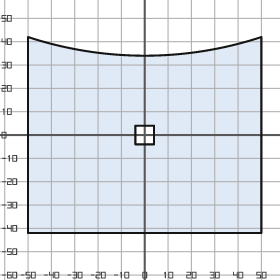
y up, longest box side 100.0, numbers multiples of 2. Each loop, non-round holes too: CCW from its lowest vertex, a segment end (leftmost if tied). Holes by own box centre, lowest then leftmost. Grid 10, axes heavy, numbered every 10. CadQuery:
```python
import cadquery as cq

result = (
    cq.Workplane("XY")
    .moveTo(-50.0, -42.0)
    .lineTo(50.0, -42.0)
    .lineTo(50.0, 42.0)
    .threePointArc((0.0, 34.0), (-50.0, 42.0))
    .close()
    .moveTo(-4.0, -4.0)
    .lineTo(4.0, -4.0)
    .lineTo(4.0, 4.0)
    .lineTo(-4.0, 4.0)
    .close()
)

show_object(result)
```